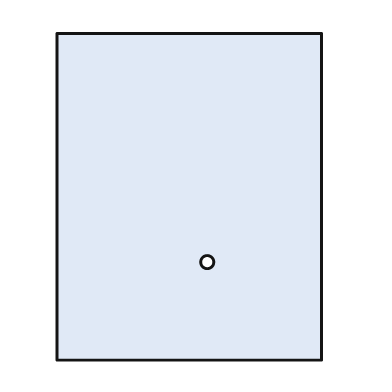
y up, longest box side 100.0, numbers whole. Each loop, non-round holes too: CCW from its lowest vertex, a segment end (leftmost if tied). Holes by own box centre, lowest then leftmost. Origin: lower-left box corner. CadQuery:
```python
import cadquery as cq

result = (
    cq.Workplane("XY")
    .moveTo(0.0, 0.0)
    .lineTo(81.0, 0.0)
    .lineTo(81.0, 100.0)
    .lineTo(0.0, 100.0)
    .close()
    .moveTo(46.0, 30.0)
    .circle(2.0)
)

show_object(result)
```